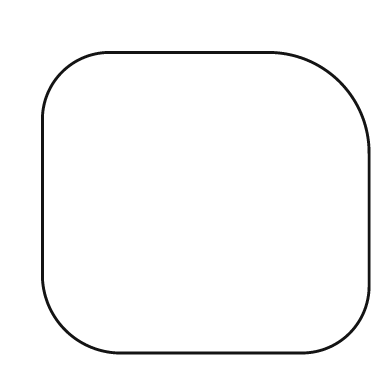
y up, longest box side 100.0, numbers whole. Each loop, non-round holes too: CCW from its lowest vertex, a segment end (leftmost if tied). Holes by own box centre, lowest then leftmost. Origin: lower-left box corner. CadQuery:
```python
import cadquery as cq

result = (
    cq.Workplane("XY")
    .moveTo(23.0, 0.0)
    .lineTo(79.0, 0.0)
    .threePointArc((94.0, 6.0), (100.0, 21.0))
    .lineTo(100.0, 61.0)
    .threePointArc((91.0, 83.0), (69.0, 92.0))
    .lineTo(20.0, 92.0)
    .threePointArc((6.0, 86.0), (0.0, 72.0))
    .lineTo(0.0, 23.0)
    .threePointArc((7.0, 7.0), (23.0, 0.0))
    .close()
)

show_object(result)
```